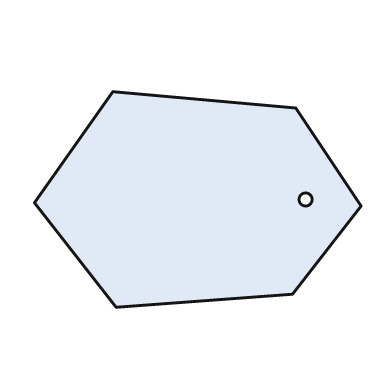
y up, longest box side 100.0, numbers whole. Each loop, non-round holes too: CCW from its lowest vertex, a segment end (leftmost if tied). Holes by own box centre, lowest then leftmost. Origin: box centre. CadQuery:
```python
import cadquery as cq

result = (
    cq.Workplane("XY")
    .moveTo(-25.0, -33.0)
    .lineTo(29.0, -29.0)
    .lineTo(50.0, -2.0)
    .lineTo(30.0, 28.0)
    .lineTo(-26.0, 33.0)
    .lineTo(-50.0, -1.0)
    .close()
    .moveTo(33.0, 0.0)
    .circle(2.0)
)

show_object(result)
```